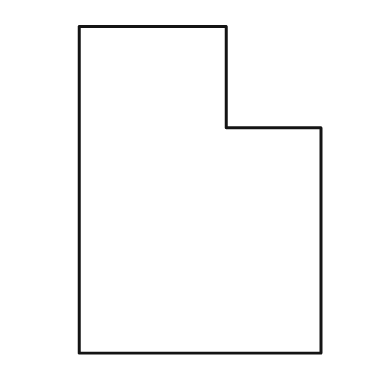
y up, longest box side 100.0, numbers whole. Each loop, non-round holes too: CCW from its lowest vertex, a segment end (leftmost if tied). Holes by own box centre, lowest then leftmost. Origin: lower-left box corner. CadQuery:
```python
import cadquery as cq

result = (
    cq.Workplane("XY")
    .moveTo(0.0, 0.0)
    .lineTo(74.0, 0.0)
    .lineTo(74.0, 69.0)
    .lineTo(45.0, 69.0)
    .lineTo(45.0, 100.0)
    .lineTo(0.0, 100.0)
    .close()
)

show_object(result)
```